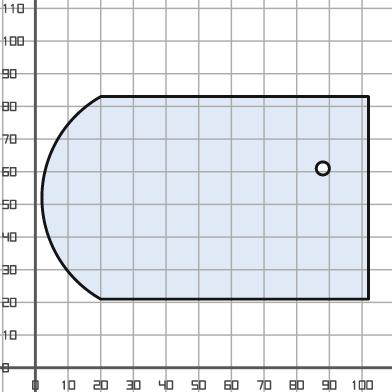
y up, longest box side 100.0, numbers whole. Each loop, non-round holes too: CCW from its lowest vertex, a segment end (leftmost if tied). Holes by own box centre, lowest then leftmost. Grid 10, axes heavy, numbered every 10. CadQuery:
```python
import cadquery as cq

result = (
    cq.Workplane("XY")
    .moveTo(20.0, 21.0)
    .lineTo(102.0, 21.0)
    .lineTo(102.0, 83.0)
    .lineTo(20.0, 83.0)
    .threePointArc((2.0, 52.0), (20.0, 21.0))
    .close()
    .moveTo(88.0, 61.0)
    .circle(2.0)
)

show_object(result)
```